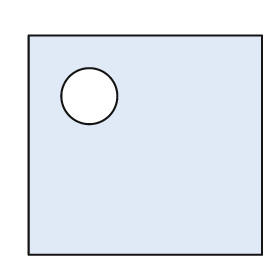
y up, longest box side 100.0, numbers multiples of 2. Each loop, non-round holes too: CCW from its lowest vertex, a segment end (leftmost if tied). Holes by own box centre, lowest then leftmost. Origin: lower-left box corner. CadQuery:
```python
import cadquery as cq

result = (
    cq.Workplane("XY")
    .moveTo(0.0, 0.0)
    .lineTo(100.0, 0.0)
    .lineTo(100.0, 94.0)
    .lineTo(0.0, 94.0)
    .close()
    .moveTo(26.0, 68.0)
    .circle(12.0)
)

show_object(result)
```